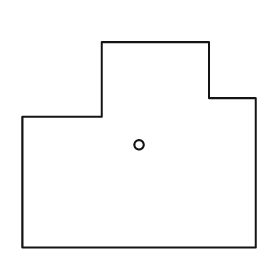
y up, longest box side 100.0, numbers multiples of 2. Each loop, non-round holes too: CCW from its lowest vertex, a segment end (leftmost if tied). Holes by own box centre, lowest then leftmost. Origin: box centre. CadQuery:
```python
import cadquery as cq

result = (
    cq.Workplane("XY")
    .moveTo(-50.0, -44.0)
    .lineTo(50.0, -44.0)
    .lineTo(50.0, 20.0)
    .lineTo(30.0, 20.0)
    .lineTo(30.0, 44.0)
    .lineTo(-16.0, 44.0)
    .lineTo(-16.0, 12.0)
    .lineTo(-50.0, 12.0)
    .close()
    .moveTo(0.0, 0.0)
    .circle(2.0)
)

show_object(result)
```